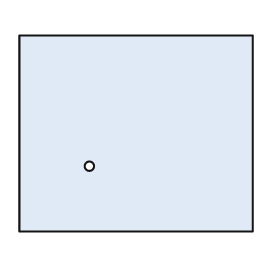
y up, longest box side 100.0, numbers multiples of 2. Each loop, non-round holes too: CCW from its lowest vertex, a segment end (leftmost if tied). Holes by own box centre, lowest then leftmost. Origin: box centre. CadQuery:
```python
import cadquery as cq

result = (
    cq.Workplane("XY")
    .moveTo(-50.0, -42.0)
    .lineTo(50.0, -42.0)
    .lineTo(50.0, 42.0)
    .lineTo(-50.0, 42.0)
    .close()
    .moveTo(-20.0, -14.0)
    .circle(2.0)
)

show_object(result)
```